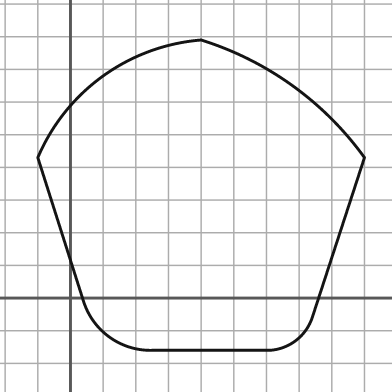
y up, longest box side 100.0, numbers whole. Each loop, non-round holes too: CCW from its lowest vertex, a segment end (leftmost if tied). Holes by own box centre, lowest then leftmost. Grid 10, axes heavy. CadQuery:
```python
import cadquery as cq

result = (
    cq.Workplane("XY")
    .moveTo(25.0, -16.0)
    .lineTo(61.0, -16.0)
    .threePointArc((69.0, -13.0), (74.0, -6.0))
    .lineTo(90.0, 43.0)
    .threePointArc((68.0, 65.0), (40.0, 79.0))
    .threePointArc((10.0, 68.0), (-10.0, 43.0))
    .lineTo(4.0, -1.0)
    .threePointArc((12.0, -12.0), (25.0, -16.0))
    .close()
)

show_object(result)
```